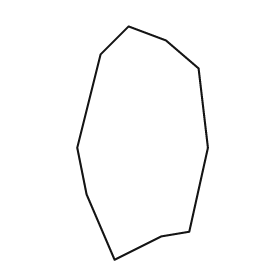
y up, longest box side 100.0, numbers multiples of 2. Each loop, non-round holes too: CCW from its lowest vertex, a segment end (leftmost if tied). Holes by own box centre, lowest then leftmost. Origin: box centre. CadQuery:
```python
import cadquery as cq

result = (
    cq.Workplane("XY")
    .moveTo(-12.0, -50.0)
    .lineTo(8.0, -40.0)
    .lineTo(20.0, -38.0)
    .lineTo(28.0, -2.0)
    .lineTo(24.0, 32.0)
    .lineTo(10.0, 44.0)
    .lineTo(-6.0, 50.0)
    .lineTo(-18.0, 38.0)
    .lineTo(-28.0, -2.0)
    .lineTo(-24.0, -22.0)
    .close()
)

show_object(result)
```